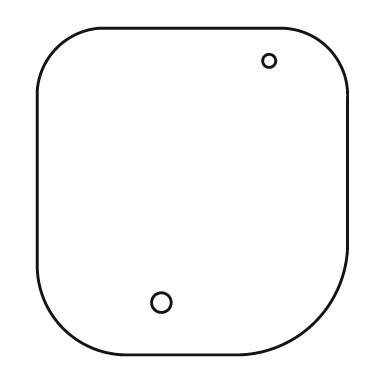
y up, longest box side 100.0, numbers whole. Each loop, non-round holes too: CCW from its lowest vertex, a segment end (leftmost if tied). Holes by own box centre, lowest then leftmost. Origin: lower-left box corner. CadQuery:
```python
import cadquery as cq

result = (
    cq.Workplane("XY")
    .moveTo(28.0, 0.0)
    .lineTo(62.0, 0.0)
    .threePointArc((85.0, 10.0), (95.0, 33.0))
    .lineTo(95.0, 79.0)
    .threePointArc((89.0, 94.0), (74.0, 100.0))
    .lineTo(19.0, 100.0)
    .threePointArc((6.0, 94.0), (0.0, 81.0))
    .lineTo(0.0, 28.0)
    .threePointArc((8.0, 8.0), (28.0, 0.0))
    .close()
    .moveTo(38.0, 16.0)
    .circle(3.0)
    .moveTo(71.0, 90.0)
    .circle(2.0)
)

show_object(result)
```